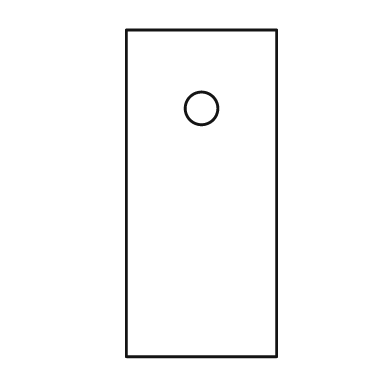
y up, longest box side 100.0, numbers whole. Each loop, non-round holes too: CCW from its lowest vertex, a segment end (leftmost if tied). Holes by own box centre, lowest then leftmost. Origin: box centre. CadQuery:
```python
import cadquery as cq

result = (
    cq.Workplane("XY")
    .moveTo(-23.0, -50.0)
    .lineTo(23.0, -50.0)
    .lineTo(23.0, 50.0)
    .lineTo(-23.0, 50.0)
    .close()
    .moveTo(0.0, 26.0)
    .circle(5.0)
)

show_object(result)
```